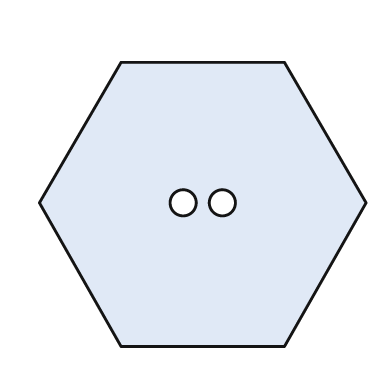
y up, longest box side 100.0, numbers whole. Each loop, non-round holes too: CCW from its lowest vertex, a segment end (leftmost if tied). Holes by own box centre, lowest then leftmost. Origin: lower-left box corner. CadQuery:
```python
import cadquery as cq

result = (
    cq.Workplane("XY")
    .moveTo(25.0, 0.0)
    .lineTo(75.0, 0.0)
    .lineTo(100.0, 44.0)
    .lineTo(75.0, 87.0)
    .lineTo(25.0, 87.0)
    .lineTo(0.0, 44.0)
    .close()
    .moveTo(44.0, 44.0)
    .circle(4.0)
    .moveTo(56.0, 44.0)
    .circle(4.0)
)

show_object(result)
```